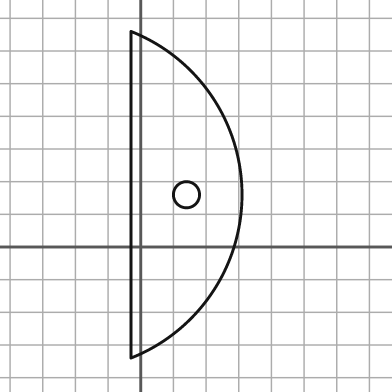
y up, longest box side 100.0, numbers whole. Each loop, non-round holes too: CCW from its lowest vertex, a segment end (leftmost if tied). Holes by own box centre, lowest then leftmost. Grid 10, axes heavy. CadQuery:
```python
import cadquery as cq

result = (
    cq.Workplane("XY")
    .moveTo(-3.0, -34.0)
    .threePointArc((31.0, 16.0), (-3.0, 66.0))
    .close()
    .moveTo(14.0, 16.0)
    .circle(4.0)
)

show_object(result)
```